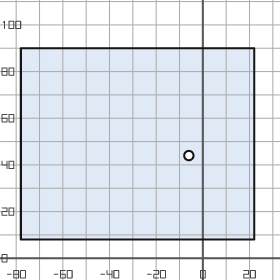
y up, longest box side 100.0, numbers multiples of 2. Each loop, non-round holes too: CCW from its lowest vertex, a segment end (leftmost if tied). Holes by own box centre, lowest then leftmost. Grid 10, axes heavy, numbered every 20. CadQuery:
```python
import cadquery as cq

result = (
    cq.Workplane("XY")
    .moveTo(-78.0, 8.0)
    .lineTo(22.0, 8.0)
    .lineTo(22.0, 90.0)
    .lineTo(-78.0, 90.0)
    .close()
    .moveTo(-6.0, 44.0)
    .circle(2.0)
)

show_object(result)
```